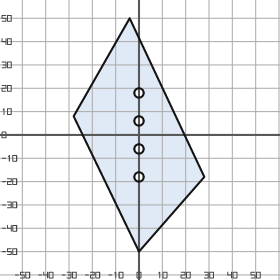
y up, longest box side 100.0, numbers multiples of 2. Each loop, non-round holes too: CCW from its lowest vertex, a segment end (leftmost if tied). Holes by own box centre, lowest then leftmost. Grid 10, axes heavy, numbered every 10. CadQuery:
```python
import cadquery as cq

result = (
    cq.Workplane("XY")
    .moveTo(0.0, -50.0)
    .lineTo(28.0, -18.0)
    .lineTo(-4.0, 50.0)
    .lineTo(-28.0, 8.0)
    .close()
    .moveTo(0.0, -18.0)
    .circle(2.0)
    .moveTo(0.0, -6.0)
    .circle(2.0)
    .moveTo(0.0, 6.0)
    .circle(2.0)
    .moveTo(0.0, 18.0)
    .circle(2.0)
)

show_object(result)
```